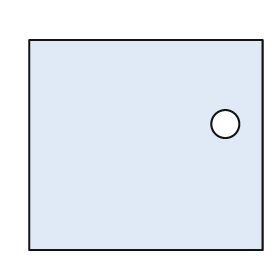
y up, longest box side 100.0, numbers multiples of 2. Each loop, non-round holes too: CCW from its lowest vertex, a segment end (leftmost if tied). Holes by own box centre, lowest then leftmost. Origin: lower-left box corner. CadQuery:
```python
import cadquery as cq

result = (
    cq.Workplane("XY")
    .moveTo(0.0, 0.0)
    .lineTo(100.0, 0.0)
    .lineTo(100.0, 90.0)
    .lineTo(0.0, 90.0)
    .close()
    .moveTo(84.0, 54.0)
    .circle(6.0)
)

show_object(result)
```